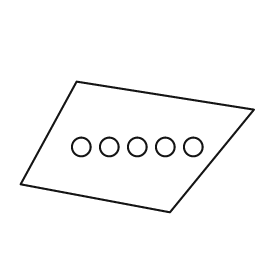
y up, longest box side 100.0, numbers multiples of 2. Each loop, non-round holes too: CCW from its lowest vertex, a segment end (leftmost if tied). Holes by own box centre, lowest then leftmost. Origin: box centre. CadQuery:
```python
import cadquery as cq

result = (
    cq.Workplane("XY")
    .moveTo(14.0, -28.0)
    .lineTo(50.0, 16.0)
    .lineTo(-26.0, 28.0)
    .lineTo(-50.0, -16.0)
    .close()
    .moveTo(-24.0, 0.0)
    .circle(4.0)
    .moveTo(-12.0, 0.0)
    .circle(4.0)
    .moveTo(0.0, 0.0)
    .circle(4.0)
    .moveTo(12.0, 0.0)
    .circle(4.0)
    .moveTo(24.0, 0.0)
    .circle(4.0)
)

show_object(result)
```